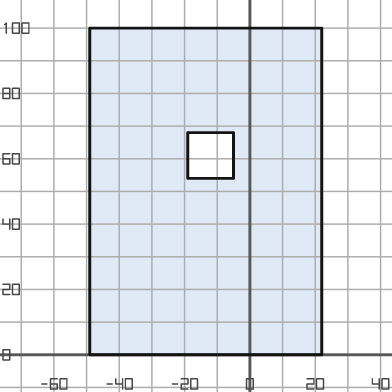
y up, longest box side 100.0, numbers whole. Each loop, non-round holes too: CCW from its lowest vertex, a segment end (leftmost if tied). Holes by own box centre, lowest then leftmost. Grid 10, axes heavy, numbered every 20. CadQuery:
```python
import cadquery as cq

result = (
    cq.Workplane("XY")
    .moveTo(-49.0, 0.0)
    .lineTo(22.0, 0.0)
    .lineTo(22.0, 100.0)
    .lineTo(-49.0, 100.0)
    .close()
    .moveTo(-19.0, 54.0)
    .lineTo(-5.0, 54.0)
    .lineTo(-5.0, 68.0)
    .lineTo(-19.0, 68.0)
    .close()
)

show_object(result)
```